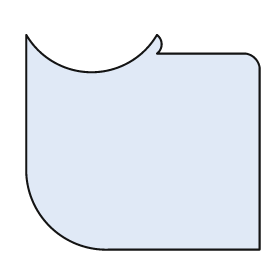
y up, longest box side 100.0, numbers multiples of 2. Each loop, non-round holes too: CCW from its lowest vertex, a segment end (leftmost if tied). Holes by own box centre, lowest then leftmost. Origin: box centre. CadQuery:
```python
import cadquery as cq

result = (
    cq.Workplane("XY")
    .moveTo(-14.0, -46.0)
    .lineTo(50.0, -46.0)
    .lineTo(50.0, 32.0)
    .threePointArc((48.0, 36.0), (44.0, 38.0))
    .lineTo(6.0, 38.0)
    .threePointArc((8.0, 42.0), (6.0, 46.0))
    .threePointArc((-22.0, 30.0), (-50.0, 46.0))
    .lineTo(-50.0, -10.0)
    .threePointArc((-40.0, -36.0), (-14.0, -46.0))
    .close()
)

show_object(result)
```